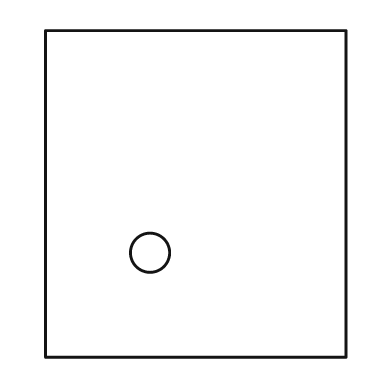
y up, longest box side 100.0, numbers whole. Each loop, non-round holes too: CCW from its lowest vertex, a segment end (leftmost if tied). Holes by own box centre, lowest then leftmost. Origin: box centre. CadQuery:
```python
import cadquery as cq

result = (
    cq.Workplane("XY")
    .moveTo(-46.0, -50.0)
    .lineTo(46.0, -50.0)
    .lineTo(46.0, 50.0)
    .lineTo(-46.0, 50.0)
    .close()
    .moveTo(-14.0, -18.0)
    .circle(6.0)
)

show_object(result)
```